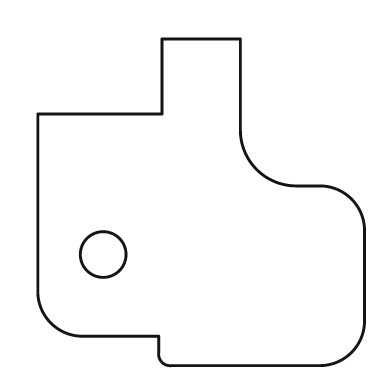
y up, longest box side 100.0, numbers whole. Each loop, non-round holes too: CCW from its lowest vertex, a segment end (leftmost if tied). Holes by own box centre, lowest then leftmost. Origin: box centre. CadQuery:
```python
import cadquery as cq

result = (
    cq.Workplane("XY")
    .moveTo(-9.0, -50.0)
    .lineTo(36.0, -50.0)
    .threePointArc((46.0, -46.0), (50.0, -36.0))
    .lineTo(50.0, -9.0)
    .threePointArc((46.0, 1.0), (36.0, 5.0))
    .lineTo(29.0, 5.0)
    .threePointArc((17.0, 10.0), (12.0, 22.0))
    .lineTo(12.0, 50.0)
    .lineTo(-12.0, 50.0)
    .lineTo(-12.0, 27.0)
    .lineTo(-50.0, 27.0)
    .lineTo(-50.0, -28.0)
    .threePointArc((-46.0, -37.0), (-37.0, -41.0))
    .lineTo(-13.0, -41.0)
    .lineTo(-13.0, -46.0)
    .threePointArc((-12.0, -49.0), (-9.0, -50.0))
    .close()
    .moveTo(-30.0, -16.0)
    .circle(7.0)
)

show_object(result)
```